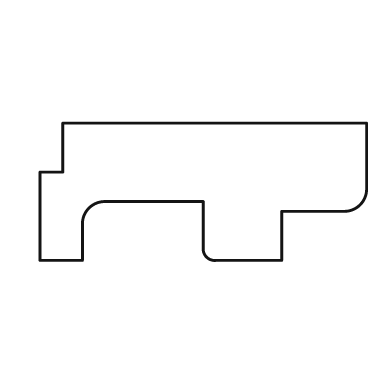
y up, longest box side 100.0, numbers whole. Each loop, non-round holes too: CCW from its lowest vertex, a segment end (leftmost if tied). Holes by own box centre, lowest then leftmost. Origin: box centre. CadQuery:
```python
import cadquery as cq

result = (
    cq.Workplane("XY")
    .moveTo(-50.0, -21.0)
    .lineTo(-37.0, -21.0)
    .lineTo(-37.0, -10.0)
    .threePointArc((-35.0, -5.0), (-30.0, -3.0))
    .lineTo(0.0, -3.0)
    .lineTo(0.0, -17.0)
    .threePointArc((1.0, -20.0), (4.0, -21.0))
    .lineTo(24.0, -21.0)
    .lineTo(24.0, -6.0)
    .lineTo(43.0, -6.0)
    .threePointArc((48.0, -4.0), (50.0, 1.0))
    .lineTo(50.0, 21.0)
    .lineTo(-43.0, 21.0)
    .lineTo(-43.0, 6.0)
    .lineTo(-50.0, 6.0)
    .close()
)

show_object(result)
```